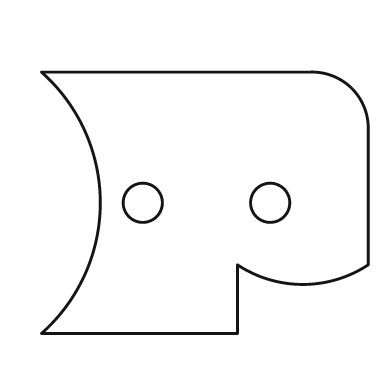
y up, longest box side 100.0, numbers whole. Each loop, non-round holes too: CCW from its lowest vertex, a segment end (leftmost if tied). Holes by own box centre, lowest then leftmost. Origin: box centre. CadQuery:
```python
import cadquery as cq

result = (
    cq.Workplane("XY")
    .moveTo(-50.0, -40.0)
    .lineTo(10.0, -40.0)
    .lineTo(10.0, -19.0)
    .threePointArc((30.0, -25.0), (50.0, -19.0))
    .lineTo(50.0, 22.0)
    .threePointArc((45.0, 35.0), (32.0, 40.0))
    .lineTo(-50.0, 40.0)
    .threePointArc((-32.0, 0.0), (-50.0, -40.0))
    .close()
    .moveTo(-19.0, 0.0)
    .circle(6.0)
    .moveTo(20.0, 0.0)
    .circle(6.0)
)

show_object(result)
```